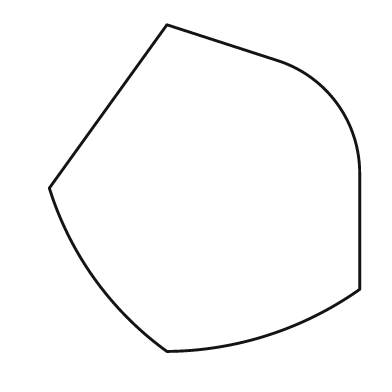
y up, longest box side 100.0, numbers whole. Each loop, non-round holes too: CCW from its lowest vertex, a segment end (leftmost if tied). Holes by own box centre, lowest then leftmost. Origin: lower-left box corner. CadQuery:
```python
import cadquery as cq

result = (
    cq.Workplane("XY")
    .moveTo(36.0, 0.0)
    .threePointArc((67.0, 5.0), (95.0, 19.0))
    .lineTo(95.0, 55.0)
    .threePointArc((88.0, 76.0), (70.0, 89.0))
    .lineTo(36.0, 100.0)
    .lineTo(0.0, 50.0)
    .threePointArc((14.0, 22.0), (36.0, 0.0))
    .close()
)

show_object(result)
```